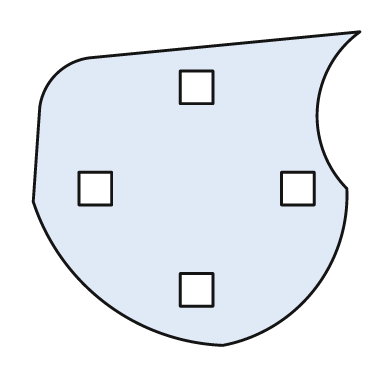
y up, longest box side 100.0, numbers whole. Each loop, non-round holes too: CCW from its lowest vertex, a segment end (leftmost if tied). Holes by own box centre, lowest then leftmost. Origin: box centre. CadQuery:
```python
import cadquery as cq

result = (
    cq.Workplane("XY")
    .moveTo(8.0, -48.0)
    .threePointArc((36.0, -31.0), (46.0, 0.0))
    .threePointArc((37.0, 25.0), (50.0, 48.0))
    .lineTo(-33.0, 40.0)
    .threePointArc((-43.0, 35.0), (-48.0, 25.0))
    .lineTo(-50.0, -4.0)
    .threePointArc((-28.0, -35.0), (8.0, -48.0))
    .close()
    .moveTo(-5.0, -36.0)
    .lineTo(5.0, -36.0)
    .lineTo(5.0, -26.0)
    .lineTo(-5.0, -26.0)
    .close()
    .moveTo(-36.0, -5.0)
    .lineTo(-26.0, -5.0)
    .lineTo(-26.0, 5.0)
    .lineTo(-36.0, 5.0)
    .close()
    .moveTo(26.0, -5.0)
    .lineTo(36.0, -5.0)
    .lineTo(36.0, 5.0)
    .lineTo(26.0, 5.0)
    .close()
    .moveTo(-5.0, 26.0)
    .lineTo(5.0, 26.0)
    .lineTo(5.0, 36.0)
    .lineTo(-5.0, 36.0)
    .close()
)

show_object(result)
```